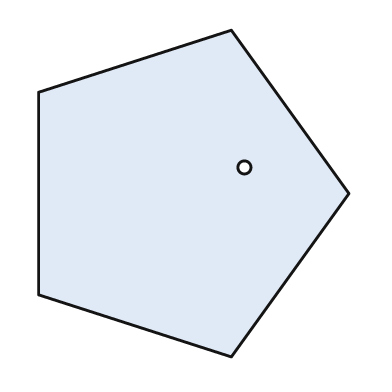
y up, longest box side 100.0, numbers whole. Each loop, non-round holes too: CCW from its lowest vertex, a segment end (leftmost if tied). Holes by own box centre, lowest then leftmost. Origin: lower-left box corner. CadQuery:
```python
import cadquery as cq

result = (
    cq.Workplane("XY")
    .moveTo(59.0, 0.0)
    .lineTo(95.0, 50.0)
    .lineTo(59.0, 100.0)
    .lineTo(0.0, 81.0)
    .lineTo(0.0, 19.0)
    .close()
    .moveTo(63.0, 58.0)
    .circle(2.0)
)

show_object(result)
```